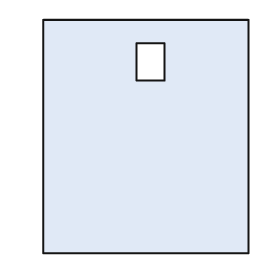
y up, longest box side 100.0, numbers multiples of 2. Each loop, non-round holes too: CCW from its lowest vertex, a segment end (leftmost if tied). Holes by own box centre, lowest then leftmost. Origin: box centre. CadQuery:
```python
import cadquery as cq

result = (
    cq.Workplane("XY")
    .moveTo(-44.0, -50.0)
    .lineTo(44.0, -50.0)
    .lineTo(44.0, 50.0)
    .lineTo(-44.0, 50.0)
    .close()
    .moveTo(-4.0, 24.0)
    .lineTo(8.0, 24.0)
    .lineTo(8.0, 40.0)
    .lineTo(-4.0, 40.0)
    .close()
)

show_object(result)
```